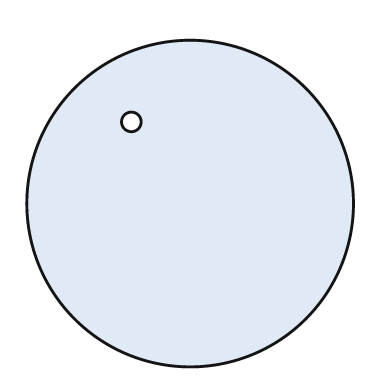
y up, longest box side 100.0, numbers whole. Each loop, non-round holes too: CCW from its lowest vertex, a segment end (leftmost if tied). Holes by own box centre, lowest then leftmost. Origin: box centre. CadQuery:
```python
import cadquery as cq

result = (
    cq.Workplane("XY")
    .moveTo(0.0, 0.0)
    .circle(50.0)
    .moveTo(-18.0, 25.0)
    .circle(3.0)
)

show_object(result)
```